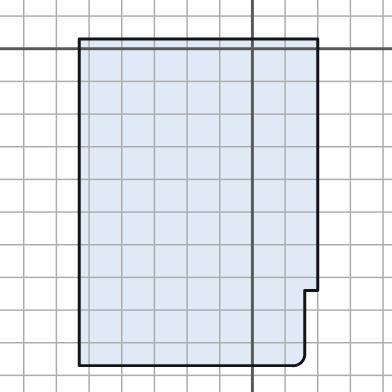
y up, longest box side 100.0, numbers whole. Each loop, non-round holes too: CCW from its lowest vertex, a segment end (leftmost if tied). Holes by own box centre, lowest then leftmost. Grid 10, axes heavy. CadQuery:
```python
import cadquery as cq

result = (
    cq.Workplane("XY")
    .moveTo(-53.0, -97.0)
    .lineTo(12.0, -97.0)
    .threePointArc((15.0, -96.0), (16.0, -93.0))
    .lineTo(16.0, -74.0)
    .lineTo(20.0, -74.0)
    .lineTo(20.0, 3.0)
    .lineTo(-53.0, 3.0)
    .close()
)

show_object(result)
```